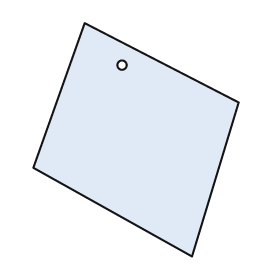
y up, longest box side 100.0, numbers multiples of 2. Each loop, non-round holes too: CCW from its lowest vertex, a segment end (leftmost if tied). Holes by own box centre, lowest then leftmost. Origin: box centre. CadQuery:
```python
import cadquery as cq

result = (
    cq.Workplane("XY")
    .moveTo(24.0, -50.0)
    .lineTo(44.0, 16.0)
    .lineTo(-22.0, 50.0)
    .lineTo(-44.0, -12.0)
    .close()
    .moveTo(-6.0, 32.0)
    .circle(2.0)
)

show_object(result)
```